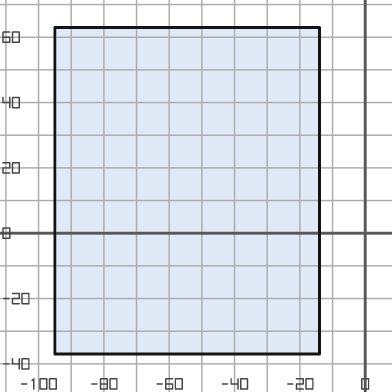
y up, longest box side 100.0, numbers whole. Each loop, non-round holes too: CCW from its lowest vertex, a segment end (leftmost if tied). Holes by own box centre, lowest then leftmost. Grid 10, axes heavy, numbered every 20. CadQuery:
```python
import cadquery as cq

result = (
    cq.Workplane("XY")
    .moveTo(-95.0, -37.0)
    .lineTo(-14.0, -37.0)
    .lineTo(-14.0, 63.0)
    .lineTo(-95.0, 63.0)
    .close()
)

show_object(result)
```